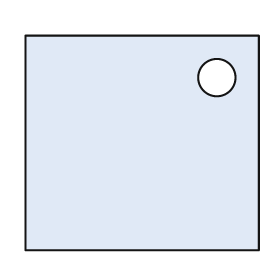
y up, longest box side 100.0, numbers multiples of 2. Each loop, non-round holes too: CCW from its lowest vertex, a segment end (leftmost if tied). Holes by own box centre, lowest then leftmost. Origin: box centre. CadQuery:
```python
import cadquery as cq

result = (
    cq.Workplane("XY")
    .moveTo(-50.0, -46.0)
    .lineTo(50.0, -46.0)
    .lineTo(50.0, 46.0)
    .lineTo(-50.0, 46.0)
    .close()
    .moveTo(32.0, 28.0)
    .circle(8.0)
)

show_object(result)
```